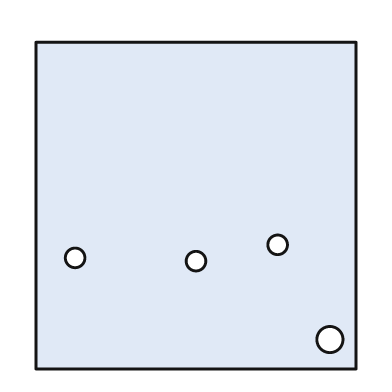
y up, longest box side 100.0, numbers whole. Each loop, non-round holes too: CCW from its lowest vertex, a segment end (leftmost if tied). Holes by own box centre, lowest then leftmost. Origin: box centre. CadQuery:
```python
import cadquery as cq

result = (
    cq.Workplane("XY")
    .moveTo(-49.0, -50.0)
    .lineTo(49.0, -50.0)
    .lineTo(49.0, 50.0)
    .lineTo(-49.0, 50.0)
    .close()
    .moveTo(41.0, -41.0)
    .circle(4.0)
    .moveTo(0.0, -17.0)
    .circle(3.0)
    .moveTo(-37.0, -16.0)
    .circle(3.0)
    .moveTo(25.0, -12.0)
    .circle(3.0)
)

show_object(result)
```